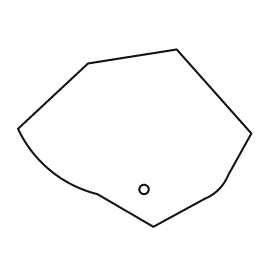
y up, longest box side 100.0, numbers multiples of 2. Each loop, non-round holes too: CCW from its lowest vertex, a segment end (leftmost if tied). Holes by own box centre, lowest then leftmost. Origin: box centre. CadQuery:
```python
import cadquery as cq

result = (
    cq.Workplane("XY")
    .moveTo(8.0, -38.0)
    .lineTo(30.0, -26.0)
    .threePointArc((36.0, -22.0), (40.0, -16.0))
    .lineTo(50.0, 2.0)
    .lineTo(18.0, 38.0)
    .lineTo(-20.0, 32.0)
    .lineTo(-50.0, 4.0)
    .threePointArc((-36.0, -14.0), (-16.0, -24.0))
    .close()
    .moveTo(4.0, -22.0)
    .circle(2.0)
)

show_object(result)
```